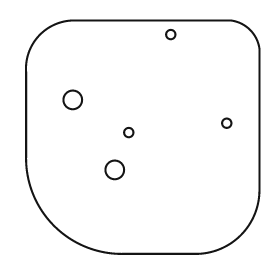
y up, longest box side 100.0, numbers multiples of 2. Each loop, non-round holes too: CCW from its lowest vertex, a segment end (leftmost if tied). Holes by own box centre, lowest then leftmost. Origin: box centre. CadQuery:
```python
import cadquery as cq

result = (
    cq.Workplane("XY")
    .moveTo(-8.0, -50.0)
    .lineTo(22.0, -50.0)
    .threePointArc((42.0, -42.0), (50.0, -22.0))
    .lineTo(50.0, 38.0)
    .threePointArc((46.0, 46.0), (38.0, 50.0))
    .lineTo(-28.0, 50.0)
    .threePointArc((-44.0, 44.0), (-50.0, 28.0))
    .lineTo(-50.0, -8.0)
    .threePointArc((-38.0, -38.0), (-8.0, -50.0))
    .close()
    .moveTo(-12.0, -14.0)
    .circle(4.0)
    .moveTo(-6.0, 2.0)
    .circle(2.0)
    .moveTo(36.0, 6.0)
    .circle(2.0)
    .moveTo(-30.0, 16.0)
    .circle(4.0)
    .moveTo(12.0, 44.0)
    .circle(2.0)
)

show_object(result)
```